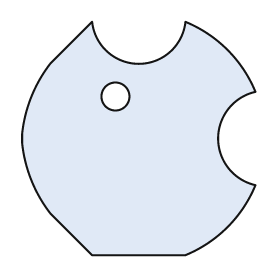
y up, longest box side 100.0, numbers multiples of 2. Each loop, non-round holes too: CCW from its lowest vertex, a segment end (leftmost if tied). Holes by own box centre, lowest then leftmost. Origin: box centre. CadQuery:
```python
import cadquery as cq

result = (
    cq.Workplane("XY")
    .moveTo(-20.0, -50.0)
    .lineTo(20.0, -50.0)
    .threePointArc((38.0, -38.0), (50.0, -20.0))
    .threePointArc((34.0, 0.0), (50.0, 20.0))
    .threePointArc((38.0, 38.0), (20.0, 50.0))
    .threePointArc((0.0, 32.0), (-20.0, 50.0))
    .lineTo(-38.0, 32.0)
    .threePointArc((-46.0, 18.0), (-50.0, 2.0))
    .lineTo(-50.0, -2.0)
    .threePointArc((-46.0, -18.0), (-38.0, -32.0))
    .close()
    .moveTo(-10.0, 18.0)
    .circle(6.0)
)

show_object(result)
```